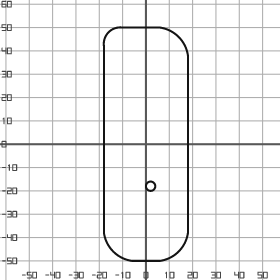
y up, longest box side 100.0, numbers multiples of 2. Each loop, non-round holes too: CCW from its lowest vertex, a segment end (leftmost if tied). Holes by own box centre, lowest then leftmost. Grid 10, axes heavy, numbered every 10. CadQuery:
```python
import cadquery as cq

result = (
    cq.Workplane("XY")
    .moveTo(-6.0, -50.0)
    .lineTo(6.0, -50.0)
    .threePointArc((14.0, -46.0), (18.0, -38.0))
    .lineTo(18.0, 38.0)
    .threePointArc((14.0, 46.0), (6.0, 50.0))
    .lineTo(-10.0, 50.0)
    .threePointArc((-16.0, 48.0), (-18.0, 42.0))
    .lineTo(-18.0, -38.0)
    .threePointArc((-14.0, -46.0), (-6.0, -50.0))
    .close()
    .moveTo(2.0, -18.0)
    .circle(2.0)
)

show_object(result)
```